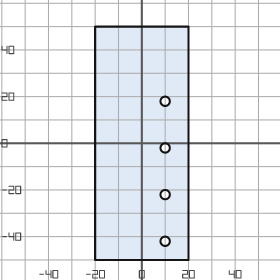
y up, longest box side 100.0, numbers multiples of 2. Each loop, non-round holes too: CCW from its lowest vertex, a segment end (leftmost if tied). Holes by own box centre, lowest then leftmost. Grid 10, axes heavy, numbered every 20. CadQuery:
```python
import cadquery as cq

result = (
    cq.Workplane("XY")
    .moveTo(-20.0, -50.0)
    .lineTo(20.0, -50.0)
    .lineTo(20.0, 50.0)
    .lineTo(-20.0, 50.0)
    .close()
    .moveTo(10.0, -42.0)
    .circle(2.0)
    .moveTo(10.0, -22.0)
    .circle(2.0)
    .moveTo(10.0, -2.0)
    .circle(2.0)
    .moveTo(10.0, 18.0)
    .circle(2.0)
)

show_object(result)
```